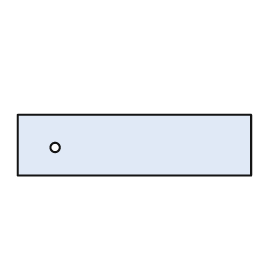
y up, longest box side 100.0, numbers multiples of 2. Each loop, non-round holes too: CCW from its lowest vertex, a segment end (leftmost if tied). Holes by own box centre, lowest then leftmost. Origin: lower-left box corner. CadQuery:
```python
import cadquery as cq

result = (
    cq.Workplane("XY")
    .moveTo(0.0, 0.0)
    .lineTo(100.0, 0.0)
    .lineTo(100.0, 26.0)
    .lineTo(0.0, 26.0)
    .close()
    .moveTo(16.0, 12.0)
    .circle(2.0)
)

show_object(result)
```